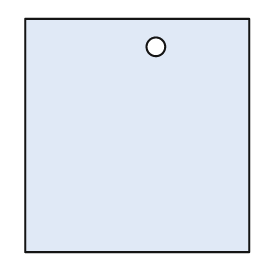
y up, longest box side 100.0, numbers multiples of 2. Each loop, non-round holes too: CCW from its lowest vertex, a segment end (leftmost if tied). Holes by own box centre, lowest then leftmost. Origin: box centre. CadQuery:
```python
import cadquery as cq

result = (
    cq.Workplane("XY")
    .moveTo(-48.0, -50.0)
    .lineTo(48.0, -50.0)
    .lineTo(48.0, 50.0)
    .lineTo(-48.0, 50.0)
    .close()
    .moveTo(8.0, 38.0)
    .circle(4.0)
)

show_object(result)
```